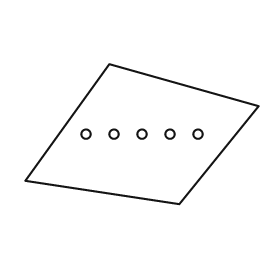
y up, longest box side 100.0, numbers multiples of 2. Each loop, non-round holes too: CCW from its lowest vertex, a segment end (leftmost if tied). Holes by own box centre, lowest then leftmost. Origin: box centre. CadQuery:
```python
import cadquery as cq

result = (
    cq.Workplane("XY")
    .moveTo(16.0, -30.0)
    .lineTo(50.0, 12.0)
    .lineTo(-14.0, 30.0)
    .lineTo(-50.0, -20.0)
    .close()
    .moveTo(-24.0, 0.0)
    .circle(2.0)
    .moveTo(-12.0, 0.0)
    .circle(2.0)
    .moveTo(0.0, 0.0)
    .circle(2.0)
    .moveTo(12.0, 0.0)
    .circle(2.0)
    .moveTo(24.0, 0.0)
    .circle(2.0)
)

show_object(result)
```